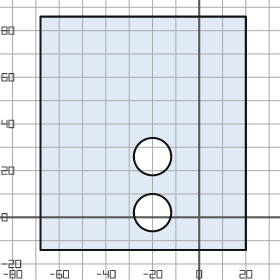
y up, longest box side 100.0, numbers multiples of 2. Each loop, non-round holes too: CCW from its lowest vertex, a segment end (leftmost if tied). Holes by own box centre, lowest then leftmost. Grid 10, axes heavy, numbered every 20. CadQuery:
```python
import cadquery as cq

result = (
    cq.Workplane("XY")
    .moveTo(-68.0, -14.0)
    .lineTo(20.0, -14.0)
    .lineTo(20.0, 86.0)
    .lineTo(-68.0, 86.0)
    .close()
    .moveTo(-20.0, 2.0)
    .circle(8.0)
    .moveTo(-20.0, 26.0)
    .circle(8.0)
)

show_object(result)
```